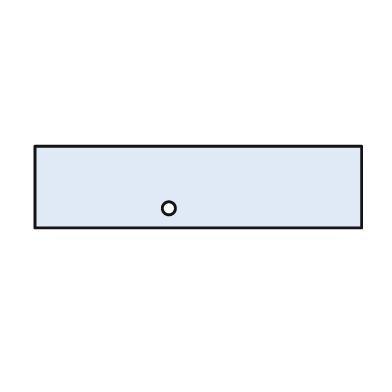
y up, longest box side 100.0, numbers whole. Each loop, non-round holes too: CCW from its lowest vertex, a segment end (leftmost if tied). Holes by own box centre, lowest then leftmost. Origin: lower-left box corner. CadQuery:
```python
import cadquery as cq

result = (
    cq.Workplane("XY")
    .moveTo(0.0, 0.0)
    .lineTo(100.0, 0.0)
    .lineTo(100.0, 25.0)
    .lineTo(0.0, 25.0)
    .close()
    .moveTo(41.0, 6.0)
    .circle(2.0)
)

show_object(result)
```